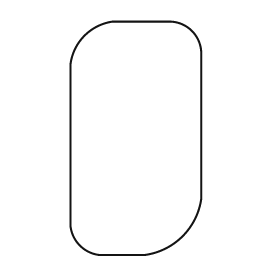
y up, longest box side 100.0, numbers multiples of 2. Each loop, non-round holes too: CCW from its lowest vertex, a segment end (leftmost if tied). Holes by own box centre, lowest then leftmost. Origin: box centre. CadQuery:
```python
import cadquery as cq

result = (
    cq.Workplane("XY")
    .moveTo(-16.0, -50.0)
    .lineTo(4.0, -50.0)
    .threePointArc((20.0, -42.0), (28.0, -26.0))
    .lineTo(28.0, 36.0)
    .threePointArc((24.0, 46.0), (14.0, 50.0))
    .lineTo(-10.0, 50.0)
    .threePointArc((-22.0, 44.0), (-28.0, 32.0))
    .lineTo(-28.0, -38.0)
    .threePointArc((-24.0, -46.0), (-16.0, -50.0))
    .close()
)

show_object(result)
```